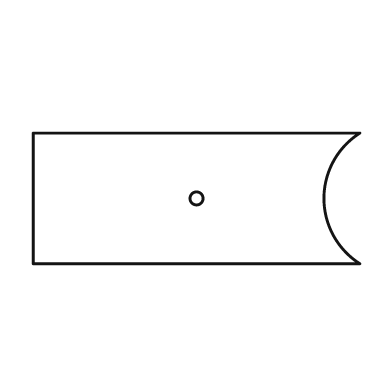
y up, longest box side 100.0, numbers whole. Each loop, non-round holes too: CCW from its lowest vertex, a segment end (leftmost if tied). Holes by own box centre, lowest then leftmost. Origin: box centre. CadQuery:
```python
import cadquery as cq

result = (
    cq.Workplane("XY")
    .moveTo(-50.0, -20.0)
    .lineTo(50.0, -20.0)
    .threePointArc((39.0, 0.0), (50.0, 20.0))
    .lineTo(-50.0, 20.0)
    .close()
    .moveTo(0.0, 0.0)
    .circle(2.0)
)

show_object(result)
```